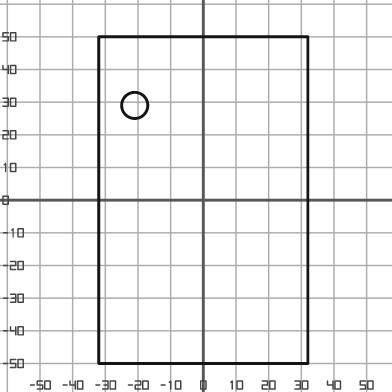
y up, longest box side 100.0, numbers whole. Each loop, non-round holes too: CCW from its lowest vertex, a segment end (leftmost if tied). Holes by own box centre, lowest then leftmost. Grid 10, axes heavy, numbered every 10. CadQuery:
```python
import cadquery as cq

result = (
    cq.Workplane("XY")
    .moveTo(-32.0, -50.0)
    .lineTo(32.0, -50.0)
    .lineTo(32.0, 50.0)
    .lineTo(-32.0, 50.0)
    .close()
    .moveTo(-21.0, 29.0)
    .circle(4.0)
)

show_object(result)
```